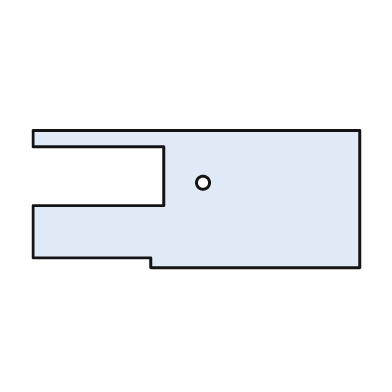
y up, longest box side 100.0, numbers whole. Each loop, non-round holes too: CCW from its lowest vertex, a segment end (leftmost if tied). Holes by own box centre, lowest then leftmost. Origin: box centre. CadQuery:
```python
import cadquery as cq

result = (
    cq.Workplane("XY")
    .moveTo(-14.0, -21.0)
    .lineTo(50.0, -21.0)
    .lineTo(50.0, 21.0)
    .lineTo(-50.0, 21.0)
    .lineTo(-50.0, 16.0)
    .lineTo(-10.0, 16.0)
    .lineTo(-10.0, -2.0)
    .lineTo(-50.0, -2.0)
    .lineTo(-50.0, -18.0)
    .lineTo(-14.0, -18.0)
    .close()
    .moveTo(2.0, 5.0)
    .circle(2.0)
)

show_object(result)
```